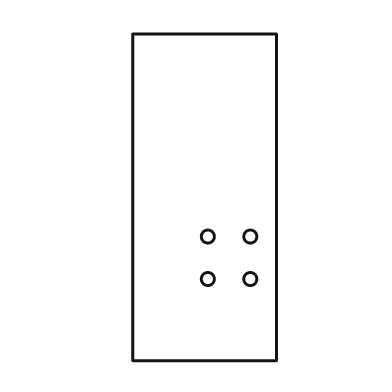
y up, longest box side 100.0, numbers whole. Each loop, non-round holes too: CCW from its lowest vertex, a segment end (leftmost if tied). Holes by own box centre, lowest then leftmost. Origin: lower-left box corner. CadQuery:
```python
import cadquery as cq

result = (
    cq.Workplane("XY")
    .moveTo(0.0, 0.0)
    .lineTo(44.0, 0.0)
    .lineTo(44.0, 100.0)
    .lineTo(0.0, 100.0)
    .close()
    .moveTo(23.0, 25.0)
    .circle(2.0)
    .moveTo(36.0, 25.0)
    .circle(2.0)
    .moveTo(23.0, 38.0)
    .circle(2.0)
    .moveTo(36.0, 38.0)
    .circle(2.0)
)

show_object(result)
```